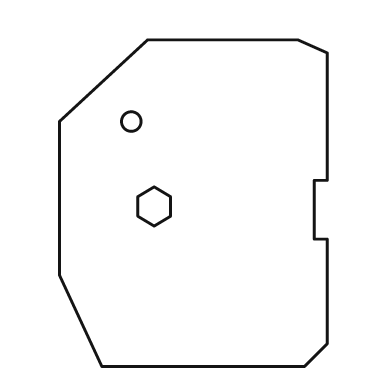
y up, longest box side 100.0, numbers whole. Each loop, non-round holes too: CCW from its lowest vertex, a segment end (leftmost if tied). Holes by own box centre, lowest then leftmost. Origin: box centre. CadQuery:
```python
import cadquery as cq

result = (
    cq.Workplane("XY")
    .moveTo(-28.0, -50.0)
    .lineTo(34.0, -50.0)
    .lineTo(41.0, -43.0)
    .lineTo(41.0, -11.0)
    .lineTo(37.0, -11.0)
    .lineTo(37.0, 7.0)
    .lineTo(41.0, 7.0)
    .lineTo(41.0, 46.0)
    .lineTo(32.0, 50.0)
    .lineTo(-14.0, 50.0)
    .lineTo(-41.0, 25.0)
    .lineTo(-41.0, -22.0)
    .close()
    .moveTo(-12.0, -7.0)
    .lineTo(-7.0, -4.0)
    .lineTo(-7.0, 2.0)
    .lineTo(-12.0, 5.0)
    .lineTo(-17.0, 2.0)
    .lineTo(-17.0, -4.0)
    .close()
    .moveTo(-19.0, 25.0)
    .circle(3.0)
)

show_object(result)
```